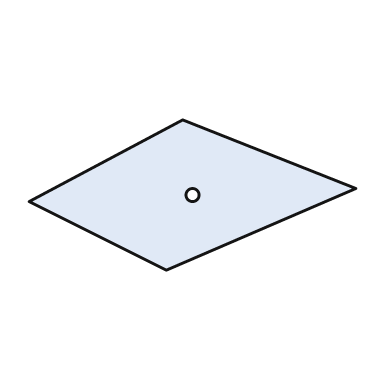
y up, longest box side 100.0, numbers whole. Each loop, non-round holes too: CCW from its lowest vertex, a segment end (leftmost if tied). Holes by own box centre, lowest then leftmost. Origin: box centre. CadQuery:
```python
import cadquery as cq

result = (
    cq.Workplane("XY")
    .moveTo(-8.0, -23.0)
    .lineTo(50.0, 2.0)
    .lineTo(-3.0, 23.0)
    .lineTo(-50.0, -2.0)
    .close()
    .moveTo(0.0, 0.0)
    .circle(2.0)
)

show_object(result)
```